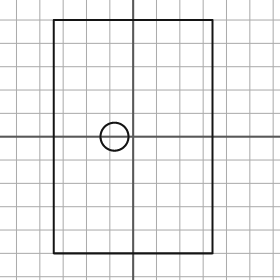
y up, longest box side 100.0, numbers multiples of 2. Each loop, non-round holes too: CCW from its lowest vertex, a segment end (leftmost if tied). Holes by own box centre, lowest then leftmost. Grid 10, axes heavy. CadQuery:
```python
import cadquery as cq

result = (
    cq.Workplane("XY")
    .moveTo(-34.0, -50.0)
    .lineTo(34.0, -50.0)
    .lineTo(34.0, 50.0)
    .lineTo(-34.0, 50.0)
    .close()
    .moveTo(-8.0, 0.0)
    .circle(6.0)
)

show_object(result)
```